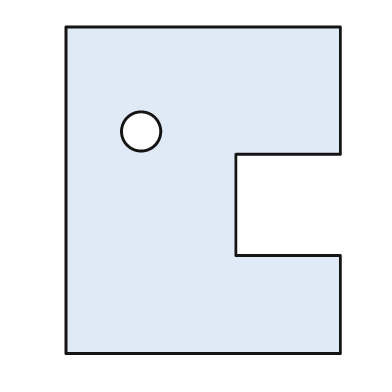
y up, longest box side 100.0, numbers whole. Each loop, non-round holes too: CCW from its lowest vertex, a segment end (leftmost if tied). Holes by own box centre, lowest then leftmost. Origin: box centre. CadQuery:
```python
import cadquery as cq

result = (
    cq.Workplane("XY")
    .moveTo(-42.0, -50.0)
    .lineTo(42.0, -50.0)
    .lineTo(42.0, -20.0)
    .lineTo(10.0, -20.0)
    .lineTo(10.0, 11.0)
    .lineTo(42.0, 11.0)
    .lineTo(42.0, 50.0)
    .lineTo(-42.0, 50.0)
    .close()
    .moveTo(-19.0, 18.0)
    .circle(6.0)
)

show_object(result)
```